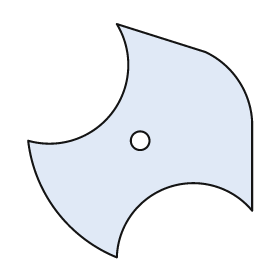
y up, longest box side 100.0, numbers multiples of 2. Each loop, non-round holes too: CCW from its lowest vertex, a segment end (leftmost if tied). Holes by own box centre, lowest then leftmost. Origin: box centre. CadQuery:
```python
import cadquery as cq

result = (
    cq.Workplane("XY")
    .moveTo(-10.0, -50.0)
    .threePointArc((12.0, -20.0), (48.0, -30.0))
    .lineTo(48.0, 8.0)
    .threePointArc((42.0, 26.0), (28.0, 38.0))
    .lineTo(-10.0, 50.0)
    .threePointArc((-12.0, 12.0), (-48.0, 0.0))
    .threePointArc((-36.0, -30.0), (-10.0, -50.0))
    .close()
    .moveTo(0.0, 0.0)
    .circle(4.0)
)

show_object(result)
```